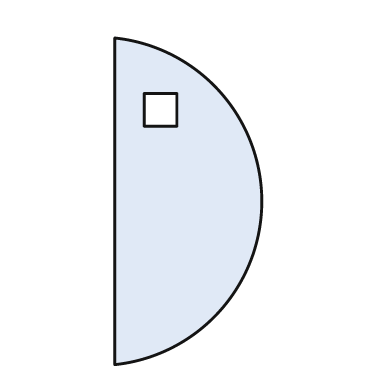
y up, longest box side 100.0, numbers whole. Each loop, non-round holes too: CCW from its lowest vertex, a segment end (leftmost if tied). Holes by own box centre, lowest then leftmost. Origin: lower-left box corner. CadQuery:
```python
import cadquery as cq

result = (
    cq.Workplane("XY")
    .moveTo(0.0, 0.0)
    .threePointArc((45.0, 50.0), (0.0, 100.0))
    .close()
    .moveTo(9.0, 73.0)
    .lineTo(19.0, 73.0)
    .lineTo(19.0, 83.0)
    .lineTo(9.0, 83.0)
    .close()
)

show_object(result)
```